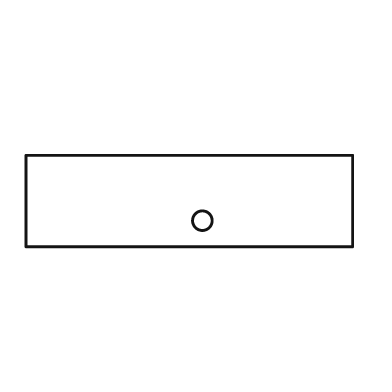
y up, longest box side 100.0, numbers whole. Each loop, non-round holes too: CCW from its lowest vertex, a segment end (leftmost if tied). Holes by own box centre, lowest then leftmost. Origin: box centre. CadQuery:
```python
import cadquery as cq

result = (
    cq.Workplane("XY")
    .moveTo(-50.0, -14.0)
    .lineTo(50.0, -14.0)
    .lineTo(50.0, 14.0)
    .lineTo(-50.0, 14.0)
    .close()
    .moveTo(4.0, -6.0)
    .circle(3.0)
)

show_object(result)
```